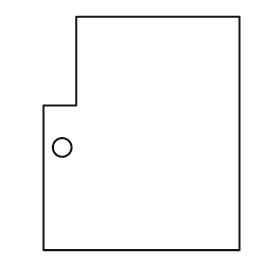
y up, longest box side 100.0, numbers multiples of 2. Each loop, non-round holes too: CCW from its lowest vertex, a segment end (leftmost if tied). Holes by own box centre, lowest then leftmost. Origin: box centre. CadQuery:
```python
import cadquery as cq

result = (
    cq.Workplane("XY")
    .moveTo(-42.0, -50.0)
    .lineTo(42.0, -50.0)
    .lineTo(42.0, 50.0)
    .lineTo(-28.0, 50.0)
    .lineTo(-28.0, 12.0)
    .lineTo(-42.0, 12.0)
    .close()
    .moveTo(-34.0, -6.0)
    .circle(4.0)
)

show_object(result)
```